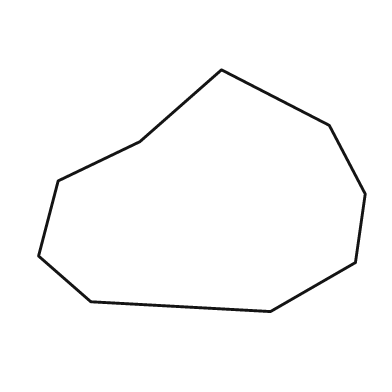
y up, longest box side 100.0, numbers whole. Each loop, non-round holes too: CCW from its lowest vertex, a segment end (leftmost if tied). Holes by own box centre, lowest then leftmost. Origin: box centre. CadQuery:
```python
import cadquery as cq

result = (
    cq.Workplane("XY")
    .moveTo(21.0, -37.0)
    .lineTo(47.0, -22.0)
    .lineTo(50.0, -1.0)
    .lineTo(39.0, 20.0)
    .lineTo(6.0, 37.0)
    .lineTo(-19.0, 15.0)
    .lineTo(-44.0, 3.0)
    .lineTo(-50.0, -20.0)
    .lineTo(-34.0, -34.0)
    .close()
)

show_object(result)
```